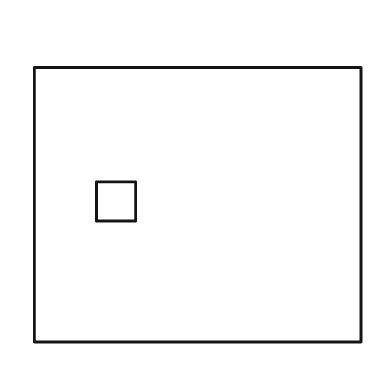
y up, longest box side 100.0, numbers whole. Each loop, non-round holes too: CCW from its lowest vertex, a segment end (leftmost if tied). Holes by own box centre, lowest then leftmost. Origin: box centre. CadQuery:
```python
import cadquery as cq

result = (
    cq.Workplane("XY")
    .moveTo(-50.0, -42.0)
    .lineTo(50.0, -42.0)
    .lineTo(50.0, 42.0)
    .lineTo(-50.0, 42.0)
    .close()
    .moveTo(-31.0, -5.0)
    .lineTo(-19.0, -5.0)
    .lineTo(-19.0, 7.0)
    .lineTo(-31.0, 7.0)
    .close()
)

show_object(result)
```